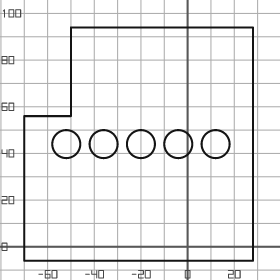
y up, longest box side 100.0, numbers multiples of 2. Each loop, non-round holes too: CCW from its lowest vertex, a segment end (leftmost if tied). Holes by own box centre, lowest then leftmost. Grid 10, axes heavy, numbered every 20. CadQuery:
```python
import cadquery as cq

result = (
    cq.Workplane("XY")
    .moveTo(-70.0, -6.0)
    .lineTo(28.0, -6.0)
    .lineTo(28.0, 94.0)
    .lineTo(-50.0, 94.0)
    .lineTo(-50.0, 56.0)
    .lineTo(-70.0, 56.0)
    .close()
    .moveTo(-52.0, 44.0)
    .circle(6.0)
    .moveTo(-36.0, 44.0)
    .circle(6.0)
    .moveTo(-20.0, 44.0)
    .circle(6.0)
    .moveTo(-4.0, 44.0)
    .circle(6.0)
    .moveTo(12.0, 44.0)
    .circle(6.0)
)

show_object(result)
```